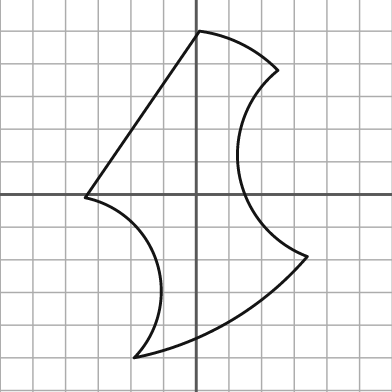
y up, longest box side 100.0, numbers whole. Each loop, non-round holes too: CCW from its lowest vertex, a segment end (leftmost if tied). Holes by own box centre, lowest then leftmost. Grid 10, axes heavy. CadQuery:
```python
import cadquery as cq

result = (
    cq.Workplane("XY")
    .moveTo(-19.0, -50.0)
    .threePointArc((10.0, -39.0), (34.0, -19.0))
    .threePointArc((13.0, 7.0), (25.0, 38.0))
    .threePointArc((14.0, 46.0), (1.0, 50.0))
    .lineTo(-34.0, -1.0)
    .threePointArc((-12.0, -21.0), (-19.0, -50.0))
    .close()
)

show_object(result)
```